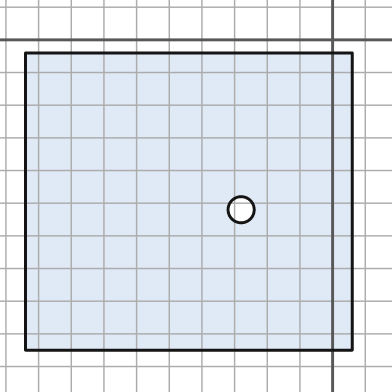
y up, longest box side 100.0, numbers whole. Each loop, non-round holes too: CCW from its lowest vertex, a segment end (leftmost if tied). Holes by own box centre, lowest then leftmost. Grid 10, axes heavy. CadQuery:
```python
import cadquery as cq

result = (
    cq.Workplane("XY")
    .moveTo(-94.0, -95.0)
    .lineTo(6.0, -95.0)
    .lineTo(6.0, -4.0)
    .lineTo(-94.0, -4.0)
    .close()
    .moveTo(-28.0, -52.0)
    .circle(4.0)
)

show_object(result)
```